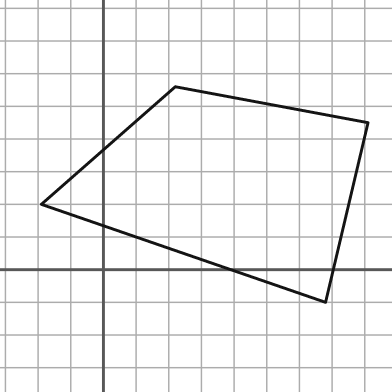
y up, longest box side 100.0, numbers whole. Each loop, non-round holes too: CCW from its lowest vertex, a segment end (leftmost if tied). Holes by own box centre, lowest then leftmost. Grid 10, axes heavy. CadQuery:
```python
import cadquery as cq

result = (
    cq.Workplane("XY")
    .moveTo(68.0, -10.0)
    .lineTo(81.0, 45.0)
    .lineTo(22.0, 56.0)
    .lineTo(-19.0, 20.0)
    .close()
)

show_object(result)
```